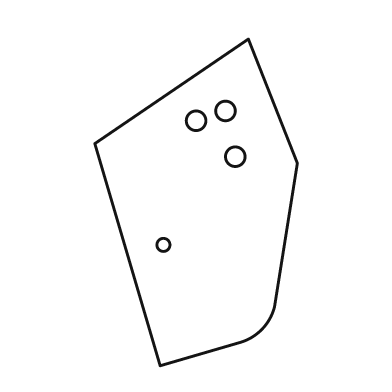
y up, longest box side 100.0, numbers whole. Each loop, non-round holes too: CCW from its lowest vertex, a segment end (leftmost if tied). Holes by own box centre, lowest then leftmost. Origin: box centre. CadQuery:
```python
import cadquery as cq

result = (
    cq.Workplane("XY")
    .moveTo(-11.0, -50.0)
    .lineTo(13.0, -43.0)
    .threePointArc((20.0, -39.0), (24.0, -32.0))
    .lineTo(31.0, 12.0)
    .lineTo(16.0, 50.0)
    .lineTo(-31.0, 18.0)
    .close()
    .moveTo(-10.0, -13.0)
    .circle(2.0)
    .moveTo(12.0, 14.0)
    .circle(3.0)
    .moveTo(0.0, 25.0)
    .circle(3.0)
    .moveTo(9.0, 28.0)
    .circle(3.0)
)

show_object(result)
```